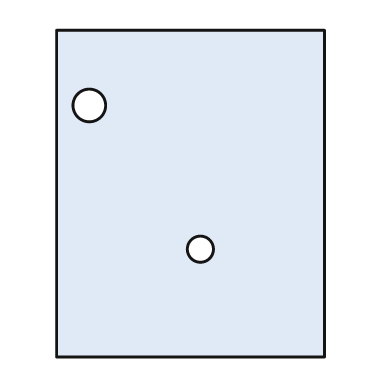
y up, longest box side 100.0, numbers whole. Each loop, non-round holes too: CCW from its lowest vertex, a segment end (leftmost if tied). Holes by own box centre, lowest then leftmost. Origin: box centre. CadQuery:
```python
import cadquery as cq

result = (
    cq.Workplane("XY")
    .moveTo(-41.0, -50.0)
    .lineTo(41.0, -50.0)
    .lineTo(41.0, 50.0)
    .lineTo(-41.0, 50.0)
    .close()
    .moveTo(3.0, -17.0)
    .circle(4.0)
    .moveTo(-31.0, 27.0)
    .circle(5.0)
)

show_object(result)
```